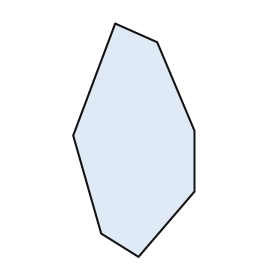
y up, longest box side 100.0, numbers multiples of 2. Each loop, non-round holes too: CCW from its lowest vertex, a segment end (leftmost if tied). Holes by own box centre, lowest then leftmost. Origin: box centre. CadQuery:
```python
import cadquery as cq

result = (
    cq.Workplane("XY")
    .moveTo(2.0, -50.0)
    .lineTo(26.0, -22.0)
    .lineTo(26.0, 4.0)
    .lineTo(10.0, 42.0)
    .lineTo(-8.0, 50.0)
    .lineTo(-26.0, 2.0)
    .lineTo(-14.0, -40.0)
    .close()
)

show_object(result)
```